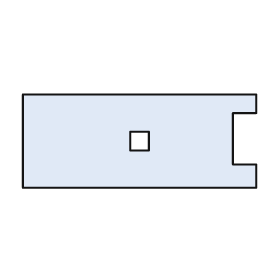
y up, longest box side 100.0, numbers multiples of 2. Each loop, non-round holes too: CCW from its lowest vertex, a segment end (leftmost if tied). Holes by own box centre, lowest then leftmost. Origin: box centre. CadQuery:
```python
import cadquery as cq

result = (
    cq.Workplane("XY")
    .moveTo(-50.0, -20.0)
    .lineTo(50.0, -20.0)
    .lineTo(50.0, -10.0)
    .lineTo(40.0, -10.0)
    .lineTo(40.0, 12.0)
    .lineTo(50.0, 12.0)
    .lineTo(50.0, 20.0)
    .lineTo(-50.0, 20.0)
    .close()
    .moveTo(-4.0, -4.0)
    .lineTo(4.0, -4.0)
    .lineTo(4.0, 4.0)
    .lineTo(-4.0, 4.0)
    .close()
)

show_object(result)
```